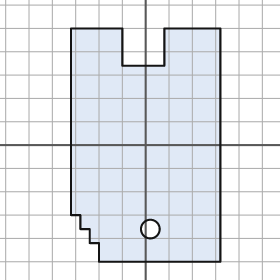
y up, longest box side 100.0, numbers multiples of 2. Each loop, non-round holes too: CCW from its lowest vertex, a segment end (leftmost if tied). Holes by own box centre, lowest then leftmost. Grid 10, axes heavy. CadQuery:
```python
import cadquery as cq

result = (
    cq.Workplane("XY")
    .moveTo(-20.0, -50.0)
    .lineTo(32.0, -50.0)
    .lineTo(32.0, 50.0)
    .lineTo(8.0, 50.0)
    .lineTo(8.0, 34.0)
    .lineTo(-10.0, 34.0)
    .lineTo(-10.0, 50.0)
    .lineTo(-32.0, 50.0)
    .lineTo(-32.0, -30.0)
    .lineTo(-28.0, -30.0)
    .lineTo(-28.0, -36.0)
    .lineTo(-24.0, -36.0)
    .lineTo(-24.0, -42.0)
    .lineTo(-20.0, -42.0)
    .close()
    .moveTo(2.0, -36.0)
    .circle(4.0)
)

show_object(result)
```